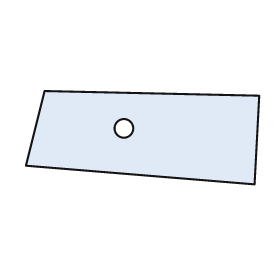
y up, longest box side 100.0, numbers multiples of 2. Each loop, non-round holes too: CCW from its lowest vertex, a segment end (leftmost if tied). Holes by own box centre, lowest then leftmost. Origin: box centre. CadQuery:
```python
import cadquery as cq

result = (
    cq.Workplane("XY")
    .moveTo(48.0, -20.0)
    .lineTo(50.0, 18.0)
    .lineTo(-42.0, 20.0)
    .lineTo(-50.0, -12.0)
    .close()
    .moveTo(-8.0, 4.0)
    .circle(4.0)
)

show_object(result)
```